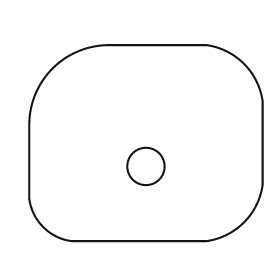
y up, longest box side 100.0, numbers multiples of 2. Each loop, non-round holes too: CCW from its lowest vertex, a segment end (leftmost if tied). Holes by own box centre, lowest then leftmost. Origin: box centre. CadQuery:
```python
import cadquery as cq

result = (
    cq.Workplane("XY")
    .moveTo(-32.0, -42.0)
    .lineTo(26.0, -42.0)
    .threePointArc((42.0, -34.0), (50.0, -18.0))
    .lineTo(50.0, 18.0)
    .threePointArc((42.0, 34.0), (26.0, 42.0))
    .lineTo(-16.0, 42.0)
    .threePointArc((-40.0, 32.0), (-50.0, 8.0))
    .lineTo(-50.0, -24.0)
    .threePointArc((-44.0, -36.0), (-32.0, -42.0))
    .close()
    .moveTo(0.0, -10.0)
    .circle(8.0)
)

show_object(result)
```